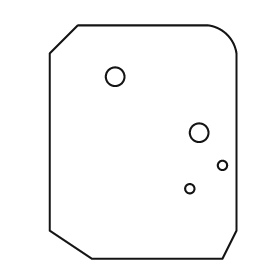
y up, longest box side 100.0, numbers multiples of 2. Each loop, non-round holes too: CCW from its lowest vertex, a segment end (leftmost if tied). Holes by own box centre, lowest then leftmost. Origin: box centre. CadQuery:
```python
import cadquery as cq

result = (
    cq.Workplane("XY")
    .moveTo(-22.0, -50.0)
    .lineTo(34.0, -50.0)
    .lineTo(40.0, -38.0)
    .lineTo(40.0, 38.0)
    .threePointArc((36.0, 46.0), (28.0, 50.0))
    .lineTo(-28.0, 50.0)
    .lineTo(-40.0, 38.0)
    .lineTo(-40.0, -38.0)
    .close()
    .moveTo(20.0, -20.0)
    .circle(2.0)
    .moveTo(34.0, -10.0)
    .circle(2.0)
    .moveTo(24.0, 4.0)
    .circle(4.0)
    .moveTo(-12.0, 28.0)
    .circle(4.0)
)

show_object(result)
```